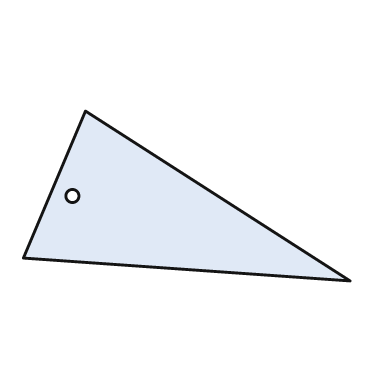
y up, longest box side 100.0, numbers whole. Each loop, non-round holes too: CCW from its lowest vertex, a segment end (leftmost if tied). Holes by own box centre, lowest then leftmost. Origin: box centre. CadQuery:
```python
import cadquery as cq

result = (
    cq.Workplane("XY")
    .moveTo(50.0, -26.0)
    .lineTo(-31.0, 26.0)
    .lineTo(-50.0, -19.0)
    .close()
    .moveTo(-35.0, 0.0)
    .circle(2.0)
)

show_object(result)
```